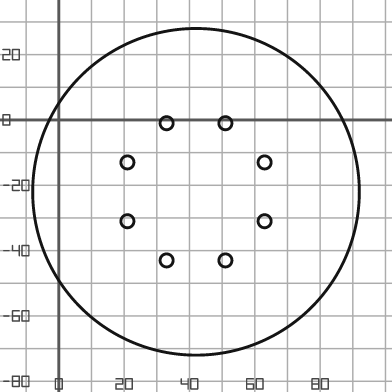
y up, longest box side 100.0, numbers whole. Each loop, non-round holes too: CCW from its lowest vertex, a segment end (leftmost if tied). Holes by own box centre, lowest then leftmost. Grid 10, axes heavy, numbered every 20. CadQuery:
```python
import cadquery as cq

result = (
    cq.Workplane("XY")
    .moveTo(42.0, -22.0)
    .circle(50.0)
    .moveTo(33.0, -43.0)
    .circle(2.0)
    .moveTo(51.0, -43.0)
    .circle(2.0)
    .moveTo(21.0, -31.0)
    .circle(2.0)
    .moveTo(63.0, -31.0)
    .circle(2.0)
    .moveTo(21.0, -13.0)
    .circle(2.0)
    .moveTo(63.0, -13.0)
    .circle(2.0)
    .moveTo(33.0, -1.0)
    .circle(2.0)
    .moveTo(51.0, -1.0)
    .circle(2.0)
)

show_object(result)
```